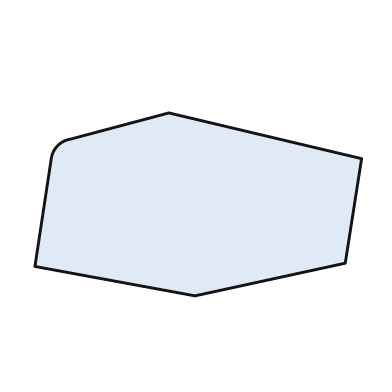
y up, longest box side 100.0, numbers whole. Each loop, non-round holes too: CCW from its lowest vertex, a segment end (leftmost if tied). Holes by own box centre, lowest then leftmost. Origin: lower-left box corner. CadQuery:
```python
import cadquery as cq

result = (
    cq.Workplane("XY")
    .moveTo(49.0, 0.0)
    .lineTo(95.0, 10.0)
    .lineTo(100.0, 42.0)
    .lineTo(41.0, 56.0)
    .lineTo(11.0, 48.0)
    .threePointArc((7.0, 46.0), (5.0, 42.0))
    .lineTo(0.0, 9.0)
    .close()
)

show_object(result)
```